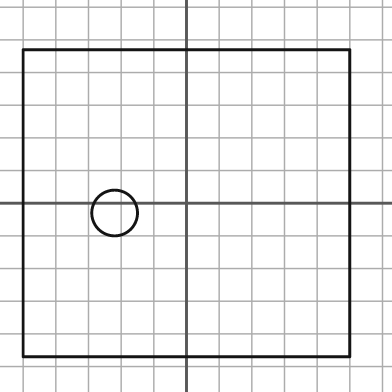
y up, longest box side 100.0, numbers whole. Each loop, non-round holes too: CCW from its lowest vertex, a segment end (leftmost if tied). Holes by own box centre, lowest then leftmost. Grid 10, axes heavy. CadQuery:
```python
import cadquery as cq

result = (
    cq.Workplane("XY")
    .moveTo(-50.0, -47.0)
    .lineTo(50.0, -47.0)
    .lineTo(50.0, 47.0)
    .lineTo(-50.0, 47.0)
    .close()
    .moveTo(-22.0, -3.0)
    .circle(7.0)
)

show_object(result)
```